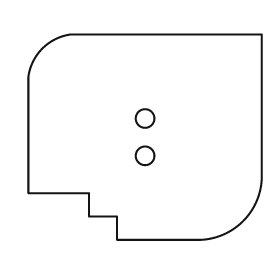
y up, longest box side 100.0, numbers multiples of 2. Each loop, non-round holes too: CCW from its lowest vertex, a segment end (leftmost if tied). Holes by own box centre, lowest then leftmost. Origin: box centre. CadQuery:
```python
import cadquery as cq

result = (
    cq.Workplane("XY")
    .moveTo(-12.0, -44.0)
    .lineTo(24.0, -44.0)
    .threePointArc((42.0, -36.0), (50.0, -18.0))
    .lineTo(50.0, 44.0)
    .lineTo(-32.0, 44.0)
    .threePointArc((-44.0, 38.0), (-50.0, 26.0))
    .lineTo(-50.0, -24.0)
    .lineTo(-24.0, -24.0)
    .lineTo(-24.0, -34.0)
    .lineTo(-12.0, -34.0)
    .close()
    .moveTo(0.0, -8.0)
    .circle(4.0)
    .moveTo(0.0, 8.0)
    .circle(4.0)
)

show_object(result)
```